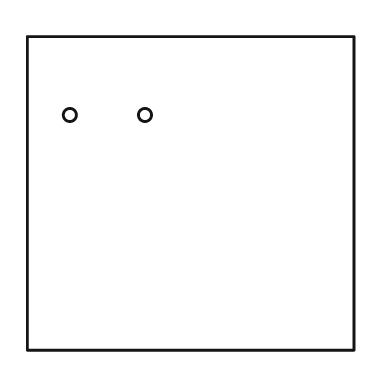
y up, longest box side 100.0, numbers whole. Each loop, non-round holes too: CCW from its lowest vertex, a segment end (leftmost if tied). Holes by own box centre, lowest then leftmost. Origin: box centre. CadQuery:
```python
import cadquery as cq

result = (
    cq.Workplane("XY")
    .moveTo(-50.0, -48.0)
    .lineTo(50.0, -48.0)
    .lineTo(50.0, 48.0)
    .lineTo(-50.0, 48.0)
    .close()
    .moveTo(-37.0, 24.0)
    .circle(2.0)
    .moveTo(-14.0, 24.0)
    .circle(2.0)
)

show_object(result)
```